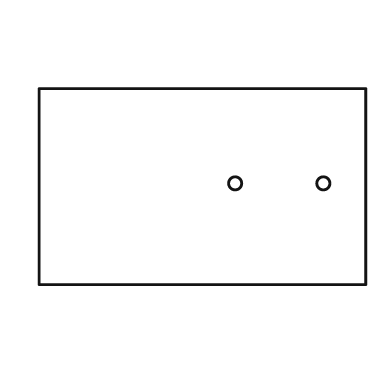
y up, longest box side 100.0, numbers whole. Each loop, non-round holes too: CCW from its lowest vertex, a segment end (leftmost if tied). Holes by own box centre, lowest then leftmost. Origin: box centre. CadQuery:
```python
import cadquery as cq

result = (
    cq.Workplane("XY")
    .moveTo(-50.0, -30.0)
    .lineTo(50.0, -30.0)
    .lineTo(50.0, 30.0)
    .lineTo(-50.0, 30.0)
    .close()
    .moveTo(10.0, 1.0)
    .circle(2.0)
    .moveTo(37.0, 1.0)
    .circle(2.0)
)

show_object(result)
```